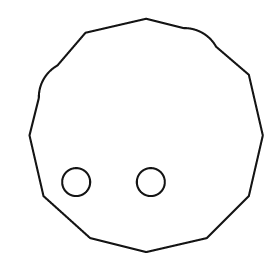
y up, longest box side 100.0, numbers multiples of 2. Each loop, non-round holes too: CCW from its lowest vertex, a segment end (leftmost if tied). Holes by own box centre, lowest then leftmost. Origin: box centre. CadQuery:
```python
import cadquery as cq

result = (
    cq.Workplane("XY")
    .moveTo(0.0, -50.0)
    .lineTo(26.0, -44.0)
    .lineTo(44.0, -26.0)
    .lineTo(50.0, 0.0)
    .lineTo(44.0, 26.0)
    .lineTo(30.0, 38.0)
    .threePointArc((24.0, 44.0), (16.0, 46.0))
    .lineTo(0.0, 50.0)
    .lineTo(-26.0, 44.0)
    .lineTo(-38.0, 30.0)
    .threePointArc((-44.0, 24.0), (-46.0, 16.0))
    .lineTo(-50.0, 0.0)
    .lineTo(-44.0, -26.0)
    .lineTo(-24.0, -44.0)
    .close()
    .moveTo(-30.0, -20.0)
    .circle(6.0)
    .moveTo(2.0, -20.0)
    .circle(6.0)
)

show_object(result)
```